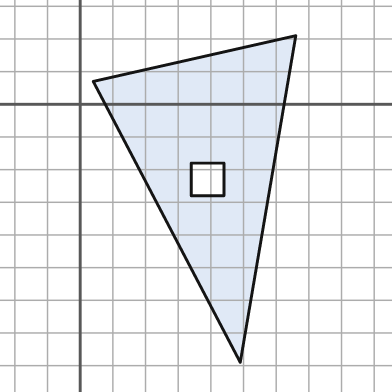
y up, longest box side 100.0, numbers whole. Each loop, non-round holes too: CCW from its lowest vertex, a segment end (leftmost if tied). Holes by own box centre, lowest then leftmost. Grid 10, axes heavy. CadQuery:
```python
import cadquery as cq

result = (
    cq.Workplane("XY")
    .moveTo(49.0, -79.0)
    .lineTo(66.0, 21.0)
    .lineTo(4.0, 7.0)
    .close()
    .moveTo(34.0, -28.0)
    .lineTo(44.0, -28.0)
    .lineTo(44.0, -18.0)
    .lineTo(34.0, -18.0)
    .close()
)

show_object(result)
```